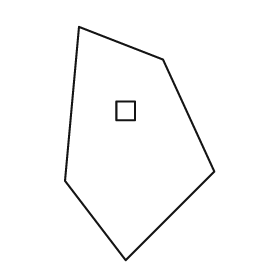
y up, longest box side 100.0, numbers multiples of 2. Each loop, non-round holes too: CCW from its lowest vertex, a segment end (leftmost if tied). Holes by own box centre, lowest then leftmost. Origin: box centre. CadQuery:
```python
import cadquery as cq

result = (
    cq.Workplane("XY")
    .moveTo(-6.0, -50.0)
    .lineTo(32.0, -12.0)
    .lineTo(10.0, 36.0)
    .lineTo(-26.0, 50.0)
    .lineTo(-32.0, -16.0)
    .close()
    .moveTo(-10.0, 10.0)
    .lineTo(-2.0, 10.0)
    .lineTo(-2.0, 18.0)
    .lineTo(-10.0, 18.0)
    .close()
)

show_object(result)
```